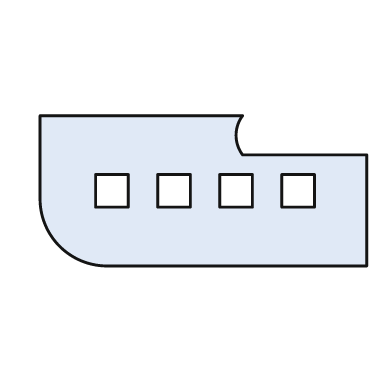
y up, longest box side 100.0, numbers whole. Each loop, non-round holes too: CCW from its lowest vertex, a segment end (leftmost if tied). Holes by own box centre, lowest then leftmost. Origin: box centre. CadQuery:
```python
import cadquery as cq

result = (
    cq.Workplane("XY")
    .moveTo(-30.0, -23.0)
    .lineTo(50.0, -23.0)
    .lineTo(50.0, 11.0)
    .lineTo(12.0, 11.0)
    .threePointArc((10.0, 17.0), (12.0, 23.0))
    .lineTo(-50.0, 23.0)
    .lineTo(-50.0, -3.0)
    .threePointArc((-44.0, -17.0), (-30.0, -23.0))
    .close()
    .moveTo(-33.0, -5.0)
    .lineTo(-23.0, -5.0)
    .lineTo(-23.0, 5.0)
    .lineTo(-33.0, 5.0)
    .close()
    .moveTo(-14.0, -5.0)
    .lineTo(-4.0, -5.0)
    .lineTo(-4.0, 5.0)
    .lineTo(-14.0, 5.0)
    .close()
    .moveTo(5.0, -5.0)
    .lineTo(15.0, -5.0)
    .lineTo(15.0, 5.0)
    .lineTo(5.0, 5.0)
    .close()
    .moveTo(24.0, -5.0)
    .lineTo(34.0, -5.0)
    .lineTo(34.0, 5.0)
    .lineTo(24.0, 5.0)
    .close()
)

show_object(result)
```